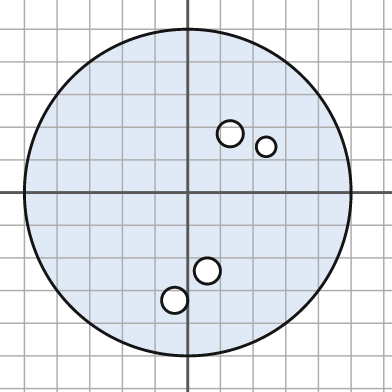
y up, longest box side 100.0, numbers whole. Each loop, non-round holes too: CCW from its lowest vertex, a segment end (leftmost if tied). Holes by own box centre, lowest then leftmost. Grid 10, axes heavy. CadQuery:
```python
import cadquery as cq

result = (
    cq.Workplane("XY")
    .moveTo(0.0, 0.0)
    .circle(50.0)
    .moveTo(-4.0, -33.0)
    .circle(4.0)
    .moveTo(6.0, -24.0)
    .circle(4.0)
    .moveTo(24.0, 14.0)
    .circle(3.0)
    .moveTo(13.0, 18.0)
    .circle(4.0)
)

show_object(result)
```